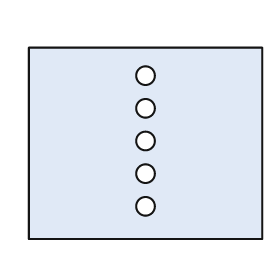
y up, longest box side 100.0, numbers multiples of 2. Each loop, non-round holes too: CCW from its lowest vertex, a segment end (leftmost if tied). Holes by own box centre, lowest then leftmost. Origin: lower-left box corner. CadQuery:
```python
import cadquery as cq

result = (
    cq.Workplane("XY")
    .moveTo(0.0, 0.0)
    .lineTo(100.0, 0.0)
    .lineTo(100.0, 82.0)
    .lineTo(0.0, 82.0)
    .close()
    .moveTo(50.0, 14.0)
    .circle(4.0)
    .moveTo(50.0, 28.0)
    .circle(4.0)
    .moveTo(50.0, 42.0)
    .circle(4.0)
    .moveTo(50.0, 56.0)
    .circle(4.0)
    .moveTo(50.0, 70.0)
    .circle(4.0)
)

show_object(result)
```